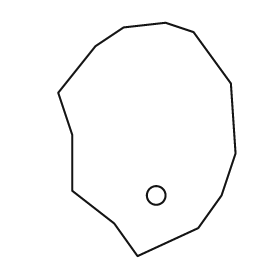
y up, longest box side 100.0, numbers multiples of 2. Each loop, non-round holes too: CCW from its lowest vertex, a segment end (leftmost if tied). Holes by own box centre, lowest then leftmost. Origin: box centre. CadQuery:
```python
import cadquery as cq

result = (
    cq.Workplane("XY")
    .moveTo(-4.0, -50.0)
    .lineTo(22.0, -38.0)
    .lineTo(32.0, -24.0)
    .lineTo(38.0, -6.0)
    .lineTo(36.0, 24.0)
    .lineTo(20.0, 46.0)
    .lineTo(8.0, 50.0)
    .lineTo(-10.0, 48.0)
    .lineTo(-22.0, 40.0)
    .lineTo(-38.0, 20.0)
    .lineTo(-32.0, 2.0)
    .lineTo(-32.0, -22.0)
    .lineTo(-14.0, -36.0)
    .close()
    .moveTo(4.0, -24.0)
    .circle(4.0)
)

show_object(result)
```